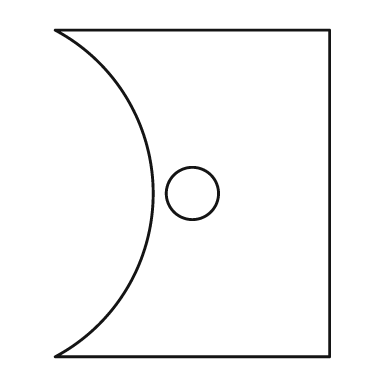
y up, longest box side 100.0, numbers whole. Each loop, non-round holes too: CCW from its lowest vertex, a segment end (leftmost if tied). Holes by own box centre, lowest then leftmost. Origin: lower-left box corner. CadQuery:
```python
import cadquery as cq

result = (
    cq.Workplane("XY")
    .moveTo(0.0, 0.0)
    .lineTo(84.0, 0.0)
    .lineTo(84.0, 100.0)
    .lineTo(0.0, 100.0)
    .threePointArc((30.0, 50.0), (0.0, 0.0))
    .close()
    .moveTo(42.0, 50.0)
    .circle(8.0)
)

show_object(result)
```